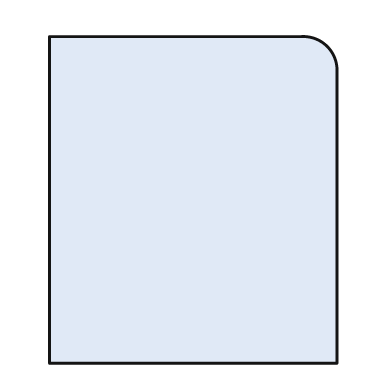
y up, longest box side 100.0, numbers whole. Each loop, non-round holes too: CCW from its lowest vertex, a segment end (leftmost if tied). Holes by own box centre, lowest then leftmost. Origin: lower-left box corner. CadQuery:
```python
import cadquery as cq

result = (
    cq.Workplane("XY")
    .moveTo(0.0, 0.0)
    .lineTo(88.0, 0.0)
    .lineTo(88.0, 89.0)
    .threePointArc((85.0, 97.0), (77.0, 100.0))
    .lineTo(0.0, 100.0)
    .close()
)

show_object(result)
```